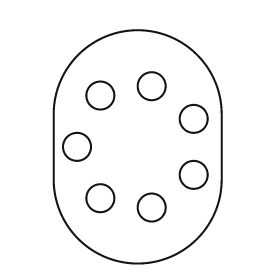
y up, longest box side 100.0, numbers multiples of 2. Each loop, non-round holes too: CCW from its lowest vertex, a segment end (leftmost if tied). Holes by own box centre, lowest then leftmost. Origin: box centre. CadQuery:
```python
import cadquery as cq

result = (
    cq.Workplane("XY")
    .moveTo(-36.0, -14.0)
    .threePointArc((0.0, -50.0), (36.0, -14.0))
    .lineTo(36.0, 14.0)
    .threePointArc((0.0, 50.0), (-36.0, 14.0))
    .close()
    .moveTo(6.0, -26.0)
    .circle(6.0)
    .moveTo(-16.0, -22.0)
    .circle(6.0)
    .moveTo(24.0, -12.0)
    .circle(6.0)
    .moveTo(-26.0, 0.0)
    .circle(6.0)
    .moveTo(24.0, 12.0)
    .circle(6.0)
    .moveTo(-16.0, 22.0)
    .circle(6.0)
    .moveTo(6.0, 26.0)
    .circle(6.0)
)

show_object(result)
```